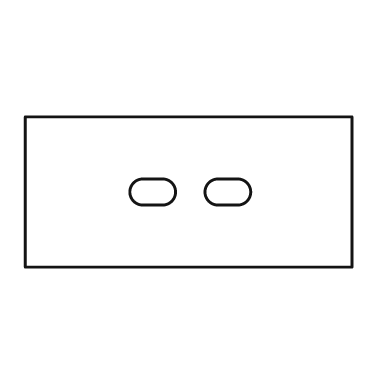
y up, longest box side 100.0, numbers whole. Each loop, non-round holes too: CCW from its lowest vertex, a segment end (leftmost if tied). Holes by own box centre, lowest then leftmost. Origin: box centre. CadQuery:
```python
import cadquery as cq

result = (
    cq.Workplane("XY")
    .moveTo(-50.0, -23.0)
    .lineTo(50.0, -23.0)
    .lineTo(50.0, 23.0)
    .lineTo(-50.0, 23.0)
    .close()
    .moveTo(-14.0, -4.0)
    .lineTo(-8.0, -4.0)
    .threePointArc((-4.0, 0.0), (-8.0, 4.0))
    .lineTo(-14.0, 4.0)
    .threePointArc((-18.0, 0.0), (-14.0, -4.0))
    .close()
    .moveTo(9.0, -4.0)
    .lineTo(15.0, -4.0)
    .threePointArc((19.0, 0.0), (15.0, 4.0))
    .lineTo(9.0, 4.0)
    .threePointArc((5.0, 0.0), (9.0, -4.0))
    .close()
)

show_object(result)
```